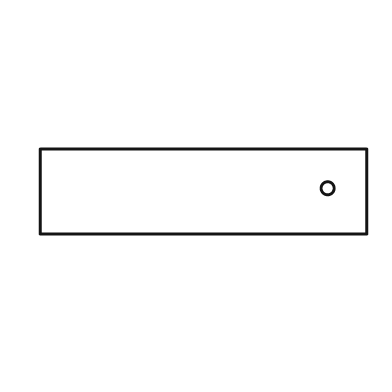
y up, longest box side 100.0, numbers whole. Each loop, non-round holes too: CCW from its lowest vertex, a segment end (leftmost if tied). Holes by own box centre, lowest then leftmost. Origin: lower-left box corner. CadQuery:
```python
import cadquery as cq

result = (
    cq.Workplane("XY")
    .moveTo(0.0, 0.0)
    .lineTo(100.0, 0.0)
    .lineTo(100.0, 26.0)
    .lineTo(0.0, 26.0)
    .close()
    .moveTo(88.0, 14.0)
    .circle(2.0)
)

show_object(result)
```